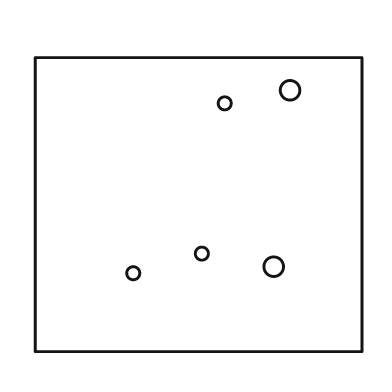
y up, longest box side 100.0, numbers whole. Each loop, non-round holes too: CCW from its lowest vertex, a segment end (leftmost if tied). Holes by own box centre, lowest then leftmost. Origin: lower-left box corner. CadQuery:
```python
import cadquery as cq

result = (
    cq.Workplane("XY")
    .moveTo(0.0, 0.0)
    .lineTo(100.0, 0.0)
    .lineTo(100.0, 90.0)
    .lineTo(0.0, 90.0)
    .close()
    .moveTo(30.0, 24.0)
    .circle(2.0)
    .moveTo(73.0, 26.0)
    .circle(3.0)
    .moveTo(51.0, 30.0)
    .circle(2.0)
    .moveTo(58.0, 76.0)
    .circle(2.0)
    .moveTo(78.0, 80.0)
    .circle(3.0)
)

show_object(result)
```